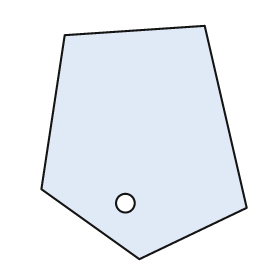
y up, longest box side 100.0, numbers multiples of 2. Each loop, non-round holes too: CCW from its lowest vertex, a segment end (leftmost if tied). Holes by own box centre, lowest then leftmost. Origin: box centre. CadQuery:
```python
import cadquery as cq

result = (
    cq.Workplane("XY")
    .moveTo(-2.0, -50.0)
    .lineTo(44.0, -28.0)
    .lineTo(26.0, 50.0)
    .lineTo(-34.0, 46.0)
    .lineTo(-44.0, -20.0)
    .close()
    .moveTo(-8.0, -26.0)
    .circle(4.0)
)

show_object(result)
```